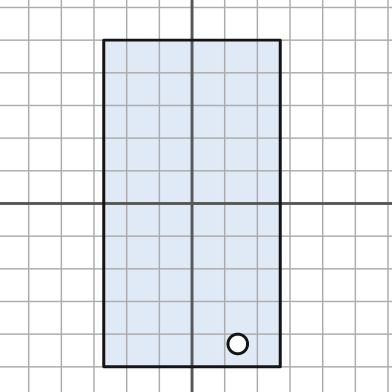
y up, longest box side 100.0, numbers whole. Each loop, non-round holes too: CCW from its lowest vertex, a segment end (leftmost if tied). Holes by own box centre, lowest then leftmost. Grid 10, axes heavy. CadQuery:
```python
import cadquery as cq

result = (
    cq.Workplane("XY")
    .moveTo(-27.0, -50.0)
    .lineTo(27.0, -50.0)
    .lineTo(27.0, 50.0)
    .lineTo(-27.0, 50.0)
    .close()
    .moveTo(14.0, -43.0)
    .circle(3.0)
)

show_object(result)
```